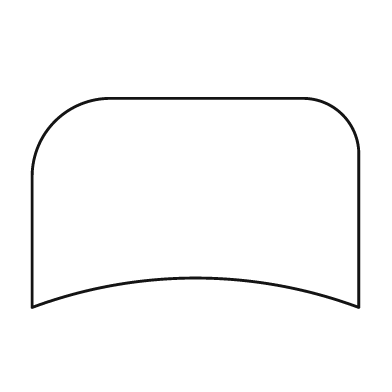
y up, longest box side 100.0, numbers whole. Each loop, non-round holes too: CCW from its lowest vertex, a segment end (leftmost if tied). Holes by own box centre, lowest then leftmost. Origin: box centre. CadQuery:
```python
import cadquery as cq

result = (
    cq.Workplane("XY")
    .moveTo(-50.0, -32.0)
    .threePointArc((0.0, -23.0), (50.0, -32.0))
    .lineTo(50.0, 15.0)
    .threePointArc((45.0, 27.0), (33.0, 32.0))
    .lineTo(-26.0, 32.0)
    .threePointArc((-43.0, 25.0), (-50.0, 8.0))
    .close()
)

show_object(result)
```